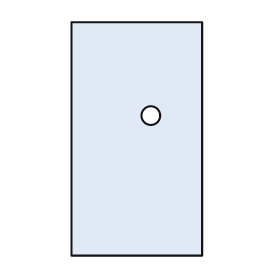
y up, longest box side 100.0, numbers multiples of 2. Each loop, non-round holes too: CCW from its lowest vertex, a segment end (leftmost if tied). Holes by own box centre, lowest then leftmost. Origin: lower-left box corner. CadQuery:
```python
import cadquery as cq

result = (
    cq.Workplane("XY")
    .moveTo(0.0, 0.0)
    .lineTo(56.0, 0.0)
    .lineTo(56.0, 100.0)
    .lineTo(0.0, 100.0)
    .close()
    .moveTo(34.0, 60.0)
    .circle(4.0)
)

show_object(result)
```